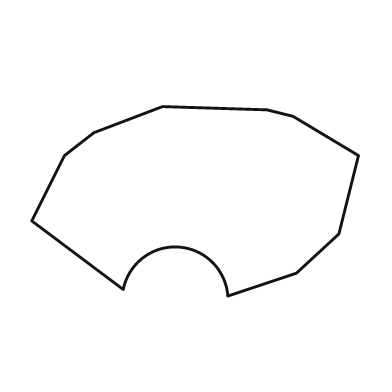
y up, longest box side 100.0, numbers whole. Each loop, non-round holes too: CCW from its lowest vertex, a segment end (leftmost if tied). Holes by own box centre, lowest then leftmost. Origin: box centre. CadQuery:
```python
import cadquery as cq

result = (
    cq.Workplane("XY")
    .moveTo(10.0, -29.0)
    .lineTo(31.0, -22.0)
    .lineTo(44.0, -10.0)
    .lineTo(50.0, 14.0)
    .lineTo(30.0, 26.0)
    .lineTo(22.0, 28.0)
    .lineTo(-10.0, 29.0)
    .lineTo(-31.0, 21.0)
    .lineTo(-40.0, 14.0)
    .lineTo(-50.0, -6.0)
    .lineTo(-22.0, -27.0)
    .threePointArc((-5.0, -14.0), (10.0, -29.0))
    .close()
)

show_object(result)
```